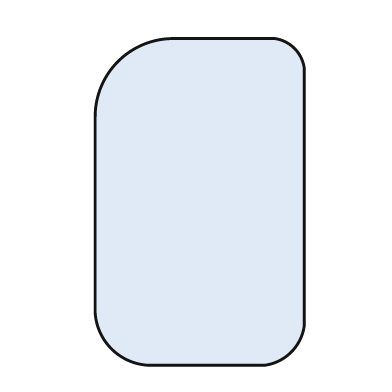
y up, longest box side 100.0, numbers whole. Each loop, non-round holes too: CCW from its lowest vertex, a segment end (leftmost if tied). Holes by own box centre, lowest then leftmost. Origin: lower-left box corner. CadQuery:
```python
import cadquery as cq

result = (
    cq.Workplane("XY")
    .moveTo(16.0, 0.0)
    .lineTo(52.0, 0.0)
    .threePointArc((60.0, 4.0), (64.0, 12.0))
    .lineTo(64.0, 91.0)
    .threePointArc((61.0, 97.0), (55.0, 100.0))
    .lineTo(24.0, 100.0)
    .threePointArc((7.0, 93.0), (0.0, 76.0))
    .lineTo(0.0, 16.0)
    .threePointArc((5.0, 5.0), (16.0, 0.0))
    .close()
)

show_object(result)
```